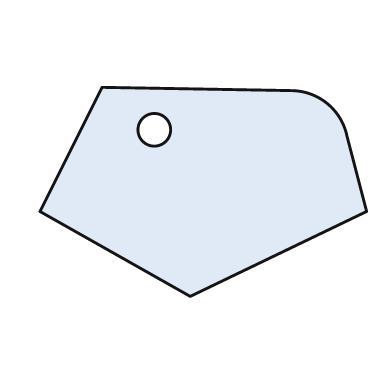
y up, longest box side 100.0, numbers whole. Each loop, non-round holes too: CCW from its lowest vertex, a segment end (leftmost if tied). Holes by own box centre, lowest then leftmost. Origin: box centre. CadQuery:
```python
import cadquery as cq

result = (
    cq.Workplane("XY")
    .moveTo(-4.0, -32.0)
    .lineTo(50.0, -6.0)
    .lineTo(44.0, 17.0)
    .threePointArc((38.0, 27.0), (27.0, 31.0))
    .lineTo(-31.0, 32.0)
    .lineTo(-50.0, -6.0)
    .close()
    .moveTo(-15.0, 19.0)
    .circle(5.0)
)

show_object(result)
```